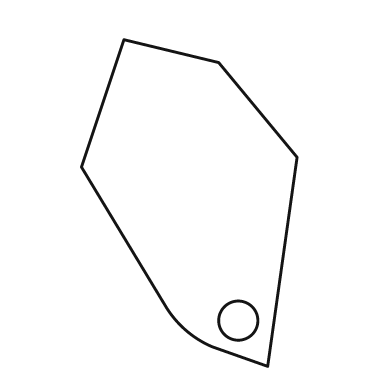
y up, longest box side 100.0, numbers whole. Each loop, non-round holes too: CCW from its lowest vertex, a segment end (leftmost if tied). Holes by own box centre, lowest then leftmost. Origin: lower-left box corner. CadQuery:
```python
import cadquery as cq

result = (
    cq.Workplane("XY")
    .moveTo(57.0, 0.0)
    .lineTo(66.0, 64.0)
    .lineTo(42.0, 93.0)
    .lineTo(13.0, 100.0)
    .lineTo(0.0, 61.0)
    .lineTo(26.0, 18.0)
    .threePointArc((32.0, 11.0), (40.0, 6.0))
    .close()
    .moveTo(48.0, 14.0)
    .circle(6.0)
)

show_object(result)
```